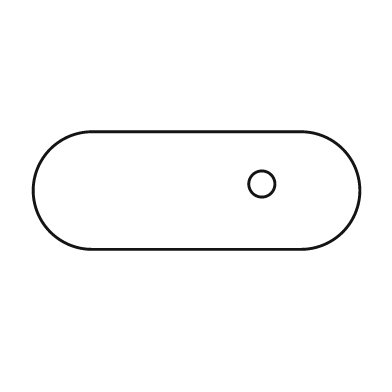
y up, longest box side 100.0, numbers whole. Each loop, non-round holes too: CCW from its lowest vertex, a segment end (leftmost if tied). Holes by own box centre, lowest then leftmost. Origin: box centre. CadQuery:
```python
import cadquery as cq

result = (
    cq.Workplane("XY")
    .moveTo(-32.0, -18.0)
    .lineTo(32.0, -18.0)
    .threePointArc((50.0, 0.0), (32.0, 18.0))
    .lineTo(-32.0, 18.0)
    .threePointArc((-50.0, 0.0), (-32.0, -18.0))
    .close()
    .moveTo(20.0, 2.0)
    .circle(4.0)
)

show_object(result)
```